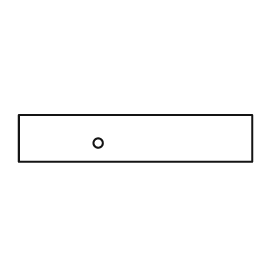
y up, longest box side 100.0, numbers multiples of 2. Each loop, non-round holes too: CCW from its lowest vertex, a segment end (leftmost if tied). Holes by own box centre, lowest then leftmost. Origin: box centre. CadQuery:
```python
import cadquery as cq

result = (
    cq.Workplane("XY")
    .moveTo(-50.0, -10.0)
    .lineTo(50.0, -10.0)
    .lineTo(50.0, 10.0)
    .lineTo(-50.0, 10.0)
    .close()
    .moveTo(-16.0, -2.0)
    .circle(2.0)
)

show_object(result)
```